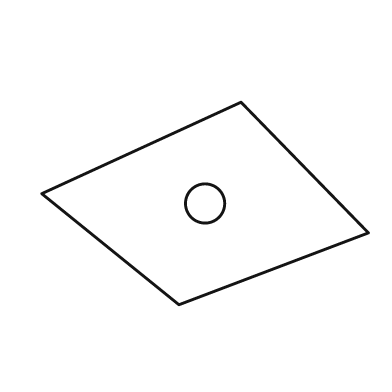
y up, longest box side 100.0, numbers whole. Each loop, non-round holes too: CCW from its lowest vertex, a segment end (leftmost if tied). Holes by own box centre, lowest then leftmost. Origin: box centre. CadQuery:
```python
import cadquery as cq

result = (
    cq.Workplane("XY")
    .moveTo(-8.0, -31.0)
    .lineTo(50.0, -9.0)
    .lineTo(11.0, 31.0)
    .lineTo(-50.0, 3.0)
    .close()
    .moveTo(0.0, 0.0)
    .circle(6.0)
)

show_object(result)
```